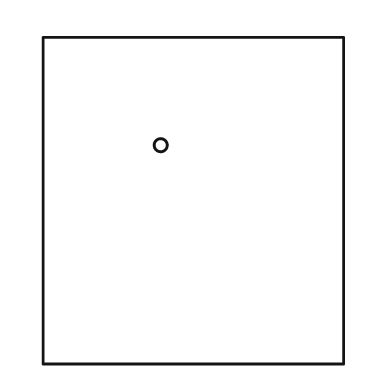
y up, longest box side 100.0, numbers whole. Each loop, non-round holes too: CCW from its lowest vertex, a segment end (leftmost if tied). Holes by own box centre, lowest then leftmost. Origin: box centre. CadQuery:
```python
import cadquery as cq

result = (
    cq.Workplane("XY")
    .moveTo(-46.0, -50.0)
    .lineTo(46.0, -50.0)
    .lineTo(46.0, 50.0)
    .lineTo(-46.0, 50.0)
    .close()
    .moveTo(-10.0, 17.0)
    .circle(2.0)
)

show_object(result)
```